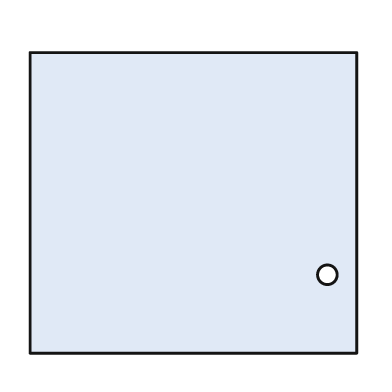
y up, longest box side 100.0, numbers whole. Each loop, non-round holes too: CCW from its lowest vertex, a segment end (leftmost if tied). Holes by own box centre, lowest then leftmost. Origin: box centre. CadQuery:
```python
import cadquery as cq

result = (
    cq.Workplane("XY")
    .moveTo(-50.0, -46.0)
    .lineTo(50.0, -46.0)
    .lineTo(50.0, 46.0)
    .lineTo(-50.0, 46.0)
    .close()
    .moveTo(41.0, -22.0)
    .circle(3.0)
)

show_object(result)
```